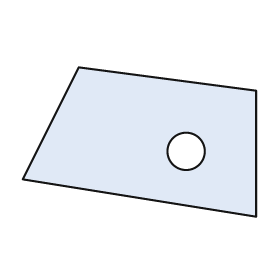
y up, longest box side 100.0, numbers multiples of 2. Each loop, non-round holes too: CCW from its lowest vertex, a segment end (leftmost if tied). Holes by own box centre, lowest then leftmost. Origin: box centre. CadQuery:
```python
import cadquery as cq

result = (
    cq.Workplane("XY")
    .moveTo(50.0, -32.0)
    .lineTo(50.0, 22.0)
    .lineTo(-26.0, 32.0)
    .lineTo(-50.0, -16.0)
    .close()
    .moveTo(20.0, -4.0)
    .circle(8.0)
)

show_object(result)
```